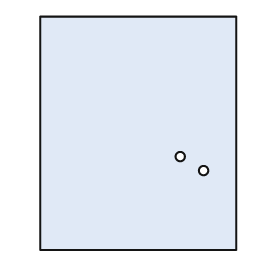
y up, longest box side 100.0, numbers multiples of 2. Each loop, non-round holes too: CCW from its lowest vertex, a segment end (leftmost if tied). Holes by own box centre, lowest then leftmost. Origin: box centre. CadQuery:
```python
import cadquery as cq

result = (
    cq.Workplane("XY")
    .moveTo(-42.0, -50.0)
    .lineTo(42.0, -50.0)
    .lineTo(42.0, 50.0)
    .lineTo(-42.0, 50.0)
    .close()
    .moveTo(28.0, -16.0)
    .circle(2.0)
    .moveTo(18.0, -10.0)
    .circle(2.0)
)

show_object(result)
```